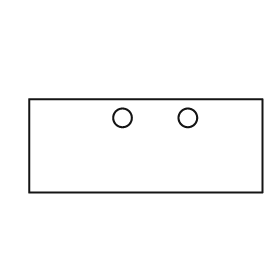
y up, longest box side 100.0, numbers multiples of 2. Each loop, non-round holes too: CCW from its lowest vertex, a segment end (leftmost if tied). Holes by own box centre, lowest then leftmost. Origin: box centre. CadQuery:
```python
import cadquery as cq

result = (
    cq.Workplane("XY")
    .moveTo(-50.0, -20.0)
    .lineTo(50.0, -20.0)
    .lineTo(50.0, 20.0)
    .lineTo(-50.0, 20.0)
    .close()
    .moveTo(-10.0, 12.0)
    .circle(4.0)
    .moveTo(18.0, 12.0)
    .circle(4.0)
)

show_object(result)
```